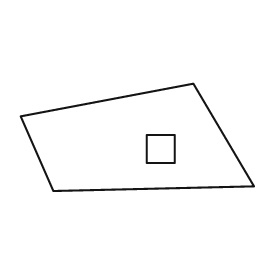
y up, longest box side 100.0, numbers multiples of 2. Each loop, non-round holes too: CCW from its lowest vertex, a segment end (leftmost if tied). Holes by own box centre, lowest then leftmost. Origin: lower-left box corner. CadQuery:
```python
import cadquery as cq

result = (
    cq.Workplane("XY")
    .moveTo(14.0, 0.0)
    .lineTo(100.0, 2.0)
    .lineTo(74.0, 46.0)
    .lineTo(0.0, 32.0)
    .close()
    .moveTo(54.0, 12.0)
    .lineTo(66.0, 12.0)
    .lineTo(66.0, 24.0)
    .lineTo(54.0, 24.0)
    .close()
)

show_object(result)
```